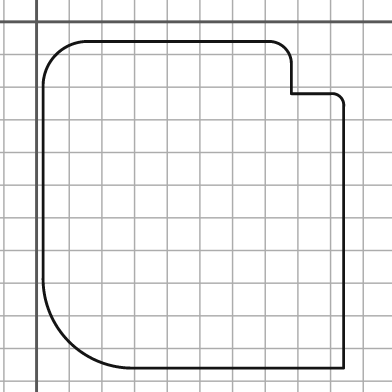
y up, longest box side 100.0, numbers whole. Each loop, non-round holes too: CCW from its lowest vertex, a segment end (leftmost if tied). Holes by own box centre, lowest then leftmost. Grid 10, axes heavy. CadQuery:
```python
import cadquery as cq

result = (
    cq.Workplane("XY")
    .moveTo(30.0, -106.0)
    .lineTo(94.0, -106.0)
    .lineTo(94.0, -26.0)
    .threePointArc((93.0, -23.0), (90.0, -22.0))
    .lineTo(78.0, -22.0)
    .lineTo(78.0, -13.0)
    .threePointArc((76.0, -8.0), (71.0, -6.0))
    .lineTo(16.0, -6.0)
    .threePointArc((6.0, -10.0), (2.0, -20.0))
    .lineTo(2.0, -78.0)
    .threePointArc((10.0, -98.0), (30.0, -106.0))
    .close()
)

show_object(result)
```